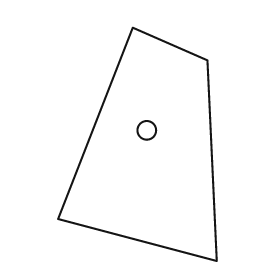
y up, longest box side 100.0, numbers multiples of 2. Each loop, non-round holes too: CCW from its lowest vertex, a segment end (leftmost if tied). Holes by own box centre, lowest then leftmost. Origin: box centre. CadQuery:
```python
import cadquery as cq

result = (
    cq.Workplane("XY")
    .moveTo(34.0, -50.0)
    .lineTo(30.0, 36.0)
    .lineTo(-2.0, 50.0)
    .lineTo(-34.0, -32.0)
    .close()
    .moveTo(4.0, 6.0)
    .circle(4.0)
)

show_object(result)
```